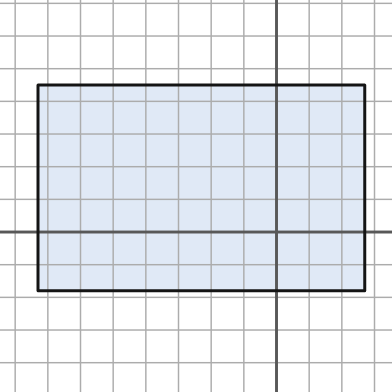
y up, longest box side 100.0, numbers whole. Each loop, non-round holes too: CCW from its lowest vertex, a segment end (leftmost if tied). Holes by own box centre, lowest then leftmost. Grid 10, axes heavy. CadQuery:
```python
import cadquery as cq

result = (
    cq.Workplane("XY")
    .moveTo(-73.0, -18.0)
    .lineTo(27.0, -18.0)
    .lineTo(27.0, 45.0)
    .lineTo(-73.0, 45.0)
    .close()
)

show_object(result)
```